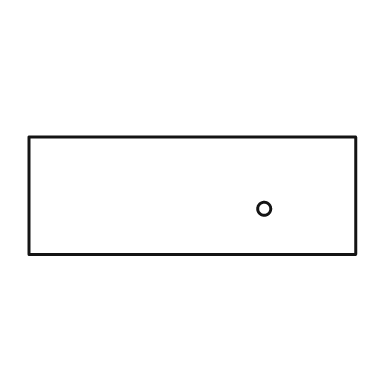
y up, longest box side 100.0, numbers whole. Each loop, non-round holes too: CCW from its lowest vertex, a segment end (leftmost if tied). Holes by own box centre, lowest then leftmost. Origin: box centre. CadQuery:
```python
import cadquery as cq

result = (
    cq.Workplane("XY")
    .moveTo(-50.0, -18.0)
    .lineTo(50.0, -18.0)
    .lineTo(50.0, 18.0)
    .lineTo(-50.0, 18.0)
    .close()
    .moveTo(22.0, -4.0)
    .circle(2.0)
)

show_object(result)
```